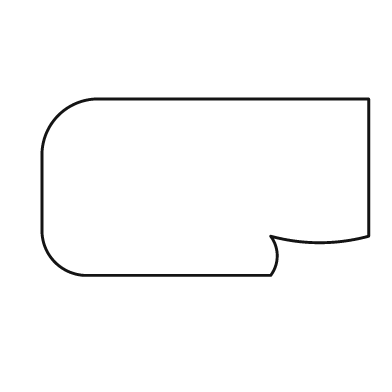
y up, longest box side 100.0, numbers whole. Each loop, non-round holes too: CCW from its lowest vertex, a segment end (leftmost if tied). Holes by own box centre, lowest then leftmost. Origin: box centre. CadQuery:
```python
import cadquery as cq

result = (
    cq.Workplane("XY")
    .moveTo(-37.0, -27.0)
    .lineTo(20.0, -27.0)
    .threePointArc((22.0, -21.0), (20.0, -15.0))
    .threePointArc((35.0, -17.0), (50.0, -15.0))
    .lineTo(50.0, 27.0)
    .lineTo(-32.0, 27.0)
    .threePointArc((-45.0, 22.0), (-50.0, 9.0))
    .lineTo(-50.0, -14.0)
    .threePointArc((-46.0, -23.0), (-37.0, -27.0))
    .close()
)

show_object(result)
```